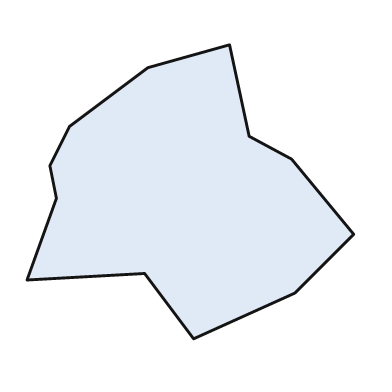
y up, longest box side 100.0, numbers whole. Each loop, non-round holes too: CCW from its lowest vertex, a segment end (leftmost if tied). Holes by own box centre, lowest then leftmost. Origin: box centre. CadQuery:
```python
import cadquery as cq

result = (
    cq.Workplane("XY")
    .moveTo(1.0, -45.0)
    .lineTo(32.0, -31.0)
    .lineTo(50.0, -13.0)
    .lineTo(31.0, 10.0)
    .lineTo(18.0, 17.0)
    .lineTo(12.0, 45.0)
    .lineTo(-13.0, 38.0)
    .lineTo(-37.0, 20.0)
    .lineTo(-43.0, 8.0)
    .lineTo(-41.0, -2.0)
    .lineTo(-50.0, -27.0)
    .lineTo(-14.0, -25.0)
    .close()
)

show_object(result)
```